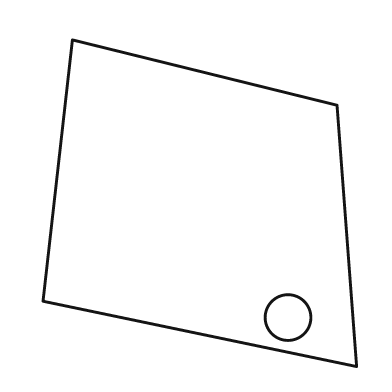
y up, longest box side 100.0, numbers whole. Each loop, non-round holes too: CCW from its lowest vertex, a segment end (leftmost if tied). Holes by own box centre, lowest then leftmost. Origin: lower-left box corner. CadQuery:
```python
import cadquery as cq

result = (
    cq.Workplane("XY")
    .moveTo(96.0, 0.0)
    .lineTo(90.0, 80.0)
    .lineTo(9.0, 100.0)
    .lineTo(0.0, 20.0)
    .close()
    .moveTo(75.0, 15.0)
    .circle(7.0)
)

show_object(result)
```